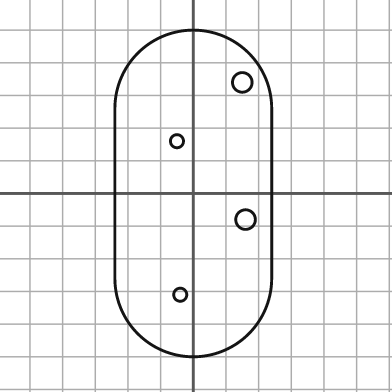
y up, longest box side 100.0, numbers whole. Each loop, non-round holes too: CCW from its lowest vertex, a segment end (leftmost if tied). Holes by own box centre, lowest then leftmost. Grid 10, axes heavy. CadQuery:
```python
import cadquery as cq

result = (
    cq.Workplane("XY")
    .moveTo(-24.0, -26.0)
    .threePointArc((0.0, -50.0), (24.0, -26.0))
    .lineTo(24.0, 26.0)
    .threePointArc((0.0, 50.0), (-24.0, 26.0))
    .close()
    .moveTo(-4.0, -31.0)
    .circle(2.0)
    .moveTo(16.0, -8.0)
    .circle(3.0)
    .moveTo(-5.0, 16.0)
    .circle(2.0)
    .moveTo(15.0, 34.0)
    .circle(3.0)
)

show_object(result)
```